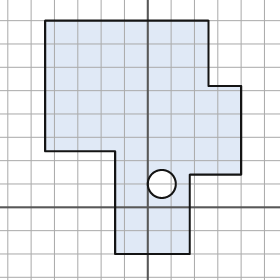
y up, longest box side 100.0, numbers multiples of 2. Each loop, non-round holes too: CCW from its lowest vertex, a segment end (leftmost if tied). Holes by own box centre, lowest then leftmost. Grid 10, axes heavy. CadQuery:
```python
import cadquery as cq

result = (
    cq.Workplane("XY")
    .moveTo(-14.0, -20.0)
    .lineTo(18.0, -20.0)
    .lineTo(18.0, 14.0)
    .lineTo(40.0, 14.0)
    .lineTo(40.0, 52.0)
    .lineTo(26.0, 52.0)
    .lineTo(26.0, 80.0)
    .lineTo(-44.0, 80.0)
    .lineTo(-44.0, 24.0)
    .lineTo(-14.0, 24.0)
    .close()
    .moveTo(6.0, 10.0)
    .circle(6.0)
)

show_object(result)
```